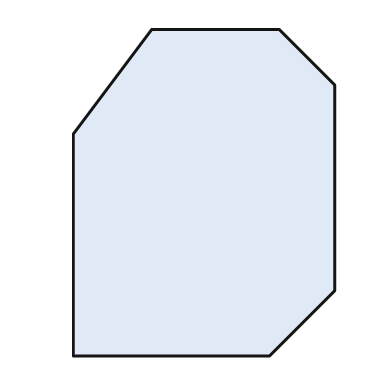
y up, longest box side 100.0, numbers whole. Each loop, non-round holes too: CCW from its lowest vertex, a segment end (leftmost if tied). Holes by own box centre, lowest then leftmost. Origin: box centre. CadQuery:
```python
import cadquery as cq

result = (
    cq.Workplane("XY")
    .moveTo(-40.0, -50.0)
    .lineTo(20.0, -50.0)
    .lineTo(40.0, -30.0)
    .lineTo(40.0, 33.0)
    .lineTo(23.0, 50.0)
    .lineTo(-16.0, 50.0)
    .lineTo(-40.0, 18.0)
    .close()
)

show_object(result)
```